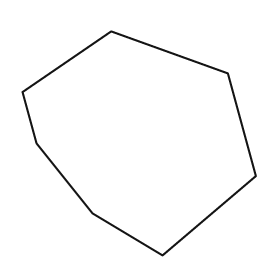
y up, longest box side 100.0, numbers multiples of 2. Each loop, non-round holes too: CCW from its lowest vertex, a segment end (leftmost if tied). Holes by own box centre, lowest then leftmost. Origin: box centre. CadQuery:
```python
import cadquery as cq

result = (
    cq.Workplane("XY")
    .moveTo(10.0, -48.0)
    .lineTo(50.0, -14.0)
    .lineTo(38.0, 30.0)
    .lineTo(-12.0, 48.0)
    .lineTo(-50.0, 22.0)
    .lineTo(-44.0, 0.0)
    .lineTo(-20.0, -30.0)
    .close()
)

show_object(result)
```